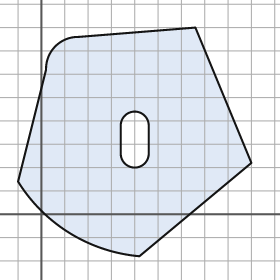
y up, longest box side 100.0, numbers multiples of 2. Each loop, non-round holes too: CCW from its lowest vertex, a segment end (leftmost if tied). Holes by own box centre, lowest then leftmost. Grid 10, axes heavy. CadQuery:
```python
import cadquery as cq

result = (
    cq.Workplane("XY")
    .moveTo(42.0, -18.0)
    .lineTo(90.0, 22.0)
    .lineTo(66.0, 80.0)
    .lineTo(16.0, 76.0)
    .threePointArc((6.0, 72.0), (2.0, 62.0))
    .lineTo(-10.0, 14.0)
    .threePointArc((12.0, -8.0), (42.0, -18.0))
    .close()
    .moveTo(34.0, 26.0)
    .threePointArc((40.0, 20.0), (46.0, 26.0))
    .lineTo(46.0, 38.0)
    .threePointArc((40.0, 44.0), (34.0, 38.0))
    .close()
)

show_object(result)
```